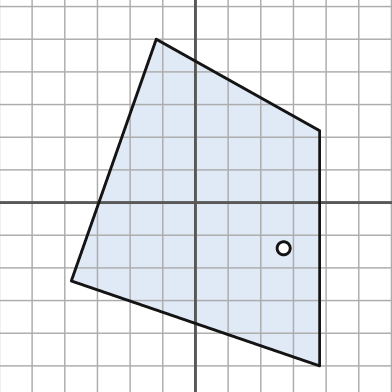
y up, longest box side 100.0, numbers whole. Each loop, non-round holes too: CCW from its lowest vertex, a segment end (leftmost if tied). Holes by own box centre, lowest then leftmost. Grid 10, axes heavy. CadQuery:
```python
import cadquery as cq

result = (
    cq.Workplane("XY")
    .moveTo(38.0, -50.0)
    .lineTo(38.0, 22.0)
    .lineTo(-12.0, 50.0)
    .lineTo(-38.0, -24.0)
    .close()
    .moveTo(27.0, -14.0)
    .circle(2.0)
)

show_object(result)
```